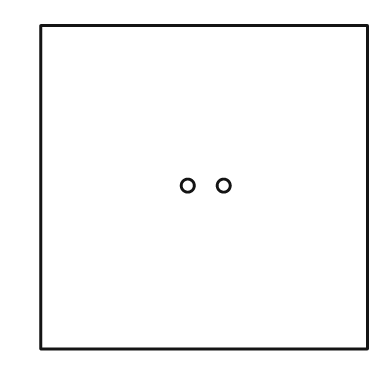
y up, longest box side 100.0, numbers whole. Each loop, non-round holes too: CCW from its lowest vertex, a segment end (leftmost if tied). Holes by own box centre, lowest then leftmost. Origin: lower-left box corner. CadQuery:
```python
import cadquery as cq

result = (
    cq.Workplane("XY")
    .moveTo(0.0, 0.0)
    .lineTo(100.0, 0.0)
    .lineTo(100.0, 99.0)
    .lineTo(0.0, 99.0)
    .close()
    .moveTo(45.0, 50.0)
    .circle(2.0)
    .moveTo(56.0, 50.0)
    .circle(2.0)
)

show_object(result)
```